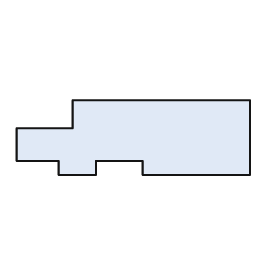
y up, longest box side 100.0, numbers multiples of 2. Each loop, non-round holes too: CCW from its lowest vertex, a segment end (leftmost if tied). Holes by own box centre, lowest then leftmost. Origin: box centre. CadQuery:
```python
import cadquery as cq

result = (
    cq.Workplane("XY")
    .moveTo(-32.0, -16.0)
    .lineTo(-16.0, -16.0)
    .lineTo(-16.0, -10.0)
    .lineTo(4.0, -10.0)
    .lineTo(4.0, -16.0)
    .lineTo(50.0, -16.0)
    .lineTo(50.0, 16.0)
    .lineTo(-26.0, 16.0)
    .lineTo(-26.0, 4.0)
    .lineTo(-50.0, 4.0)
    .lineTo(-50.0, -10.0)
    .lineTo(-32.0, -10.0)
    .close()
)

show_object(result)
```